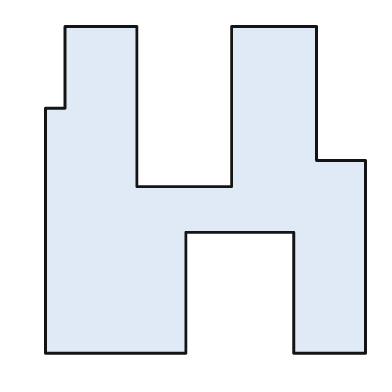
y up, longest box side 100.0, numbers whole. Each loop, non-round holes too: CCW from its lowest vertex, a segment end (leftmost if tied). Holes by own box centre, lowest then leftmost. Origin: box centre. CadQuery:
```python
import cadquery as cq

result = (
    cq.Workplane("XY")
    .moveTo(-49.0, -50.0)
    .lineTo(-6.0, -50.0)
    .lineTo(-6.0, -13.0)
    .lineTo(27.0, -13.0)
    .lineTo(27.0, -50.0)
    .lineTo(49.0, -50.0)
    .lineTo(49.0, 9.0)
    .lineTo(34.0, 9.0)
    .lineTo(34.0, 50.0)
    .lineTo(8.0, 50.0)
    .lineTo(8.0, 1.0)
    .lineTo(-21.0, 1.0)
    .lineTo(-21.0, 50.0)
    .lineTo(-43.0, 50.0)
    .lineTo(-43.0, 25.0)
    .lineTo(-49.0, 25.0)
    .close()
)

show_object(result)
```